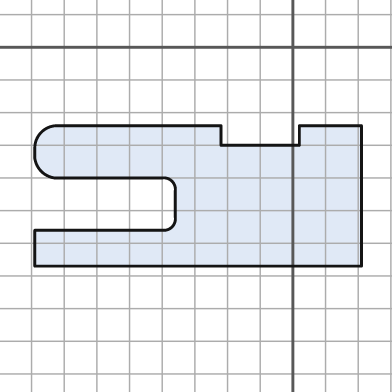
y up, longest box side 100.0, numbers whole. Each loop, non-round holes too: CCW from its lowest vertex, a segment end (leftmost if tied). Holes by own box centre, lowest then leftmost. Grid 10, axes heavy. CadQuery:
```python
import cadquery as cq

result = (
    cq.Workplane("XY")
    .moveTo(-79.0, -67.0)
    .lineTo(21.0, -67.0)
    .lineTo(21.0, -24.0)
    .lineTo(2.0, -24.0)
    .lineTo(2.0, -30.0)
    .lineTo(-22.0, -30.0)
    .lineTo(-22.0, -24.0)
    .lineTo(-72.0, -24.0)
    .threePointArc((-77.0, -26.0), (-79.0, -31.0))
    .lineTo(-79.0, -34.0)
    .threePointArc((-77.0, -38.0), (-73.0, -40.0))
    .lineTo(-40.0, -40.0)
    .threePointArc((-37.0, -41.0), (-36.0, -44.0))
    .lineTo(-36.0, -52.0)
    .threePointArc((-37.0, -55.0), (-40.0, -56.0))
    .lineTo(-79.0, -56.0)
    .close()
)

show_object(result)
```